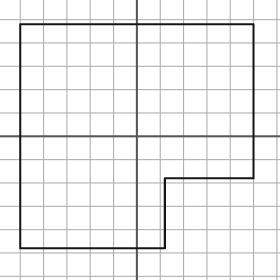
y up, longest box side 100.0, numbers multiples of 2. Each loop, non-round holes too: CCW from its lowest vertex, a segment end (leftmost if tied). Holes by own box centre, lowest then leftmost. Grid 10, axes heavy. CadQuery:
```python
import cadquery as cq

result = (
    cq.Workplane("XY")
    .moveTo(-50.0, -48.0)
    .lineTo(12.0, -48.0)
    .lineTo(12.0, -18.0)
    .lineTo(50.0, -18.0)
    .lineTo(50.0, 48.0)
    .lineTo(-50.0, 48.0)
    .close()
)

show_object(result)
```